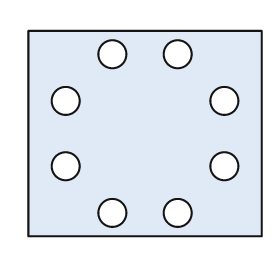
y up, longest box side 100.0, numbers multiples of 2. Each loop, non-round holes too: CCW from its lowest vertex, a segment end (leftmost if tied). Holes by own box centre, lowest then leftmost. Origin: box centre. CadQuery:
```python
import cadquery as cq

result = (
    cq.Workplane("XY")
    .moveTo(-50.0, -44.0)
    .lineTo(50.0, -44.0)
    .lineTo(50.0, 44.0)
    .lineTo(-50.0, 44.0)
    .close()
    .moveTo(-14.0, -34.0)
    .circle(6.0)
    .moveTo(14.0, -34.0)
    .circle(6.0)
    .moveTo(-34.0, -14.0)
    .circle(6.0)
    .moveTo(34.0, -14.0)
    .circle(6.0)
    .moveTo(-34.0, 14.0)
    .circle(6.0)
    .moveTo(34.0, 14.0)
    .circle(6.0)
    .moveTo(-14.0, 34.0)
    .circle(6.0)
    .moveTo(14.0, 34.0)
    .circle(6.0)
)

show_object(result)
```